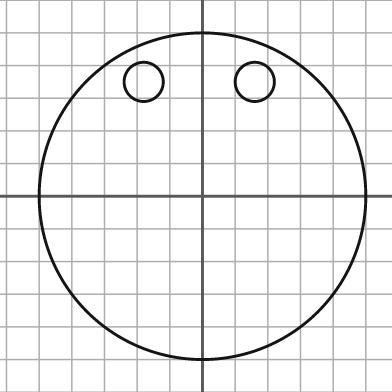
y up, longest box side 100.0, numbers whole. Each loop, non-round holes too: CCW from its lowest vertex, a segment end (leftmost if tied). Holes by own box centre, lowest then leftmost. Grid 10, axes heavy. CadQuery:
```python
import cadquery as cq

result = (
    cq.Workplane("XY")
    .moveTo(0.0, 0.0)
    .circle(50.0)
    .moveTo(-18.0, 35.0)
    .circle(6.0)
    .moveTo(16.0, 35.0)
    .circle(6.0)
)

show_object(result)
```